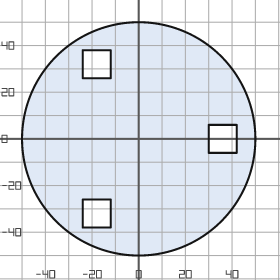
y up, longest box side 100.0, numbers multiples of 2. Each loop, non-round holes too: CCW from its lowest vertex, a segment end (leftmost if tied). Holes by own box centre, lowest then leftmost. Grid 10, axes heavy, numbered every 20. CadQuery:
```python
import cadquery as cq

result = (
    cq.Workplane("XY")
    .moveTo(0.0, 0.0)
    .circle(50.0)
    .moveTo(-24.0, -38.0)
    .lineTo(-12.0, -38.0)
    .lineTo(-12.0, -26.0)
    .lineTo(-24.0, -26.0)
    .close()
    .moveTo(30.0, -6.0)
    .lineTo(42.0, -6.0)
    .lineTo(42.0, 6.0)
    .lineTo(30.0, 6.0)
    .close()
    .moveTo(-24.0, 26.0)
    .lineTo(-12.0, 26.0)
    .lineTo(-12.0, 38.0)
    .lineTo(-24.0, 38.0)
    .close()
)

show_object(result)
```